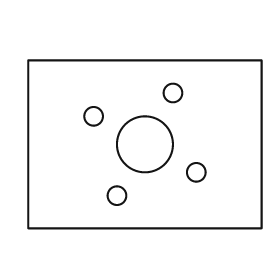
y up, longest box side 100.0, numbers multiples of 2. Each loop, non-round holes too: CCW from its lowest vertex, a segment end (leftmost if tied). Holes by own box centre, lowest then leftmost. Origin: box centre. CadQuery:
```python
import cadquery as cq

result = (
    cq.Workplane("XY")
    .moveTo(-50.0, -36.0)
    .lineTo(50.0, -36.0)
    .lineTo(50.0, 36.0)
    .lineTo(-50.0, 36.0)
    .close()
    .moveTo(-12.0, -22.0)
    .circle(4.0)
    .moveTo(22.0, -12.0)
    .circle(4.0)
    .moveTo(0.0, 0.0)
    .circle(12.0)
    .moveTo(-22.0, 12.0)
    .circle(4.0)
    .moveTo(12.0, 22.0)
    .circle(4.0)
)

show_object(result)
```